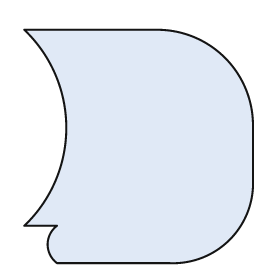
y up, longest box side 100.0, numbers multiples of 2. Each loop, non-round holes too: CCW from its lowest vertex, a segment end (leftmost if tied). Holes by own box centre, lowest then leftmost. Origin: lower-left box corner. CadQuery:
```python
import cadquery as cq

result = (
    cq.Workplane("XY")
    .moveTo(14.0, 0.0)
    .lineTo(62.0, 0.0)
    .threePointArc((88.0, 10.0), (98.0, 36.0))
    .lineTo(98.0, 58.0)
    .threePointArc((86.0, 88.0), (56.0, 100.0))
    .lineTo(0.0, 100.0)
    .threePointArc((18.0, 58.0), (0.0, 16.0))
    .lineTo(14.0, 16.0)
    .threePointArc((10.0, 8.0), (14.0, 0.0))
    .close()
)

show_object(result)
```